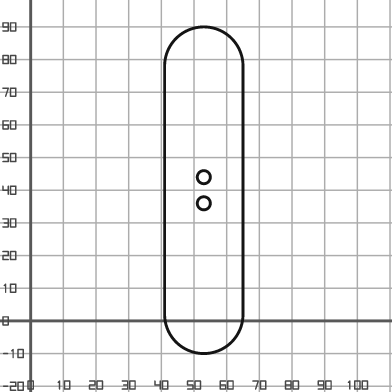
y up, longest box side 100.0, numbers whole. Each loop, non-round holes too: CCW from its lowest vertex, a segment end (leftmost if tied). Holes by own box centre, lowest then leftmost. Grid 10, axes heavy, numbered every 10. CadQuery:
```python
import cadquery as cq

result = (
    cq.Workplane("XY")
    .moveTo(41.0, 2.0)
    .threePointArc((53.0, -10.0), (65.0, 2.0))
    .lineTo(65.0, 78.0)
    .threePointArc((53.0, 90.0), (41.0, 78.0))
    .close()
    .moveTo(53.0, 36.0)
    .circle(2.0)
    .moveTo(53.0, 44.0)
    .circle(2.0)
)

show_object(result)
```